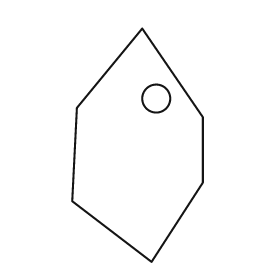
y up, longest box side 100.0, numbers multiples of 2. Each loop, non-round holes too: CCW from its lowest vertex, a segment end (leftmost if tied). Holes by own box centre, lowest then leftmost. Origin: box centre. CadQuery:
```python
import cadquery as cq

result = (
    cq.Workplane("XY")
    .moveTo(6.0, -50.0)
    .lineTo(28.0, -16.0)
    .lineTo(28.0, 12.0)
    .lineTo(2.0, 50.0)
    .lineTo(-26.0, 16.0)
    .lineTo(-28.0, -24.0)
    .close()
    .moveTo(8.0, 20.0)
    .circle(6.0)
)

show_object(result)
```